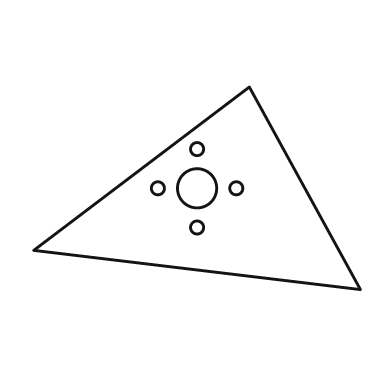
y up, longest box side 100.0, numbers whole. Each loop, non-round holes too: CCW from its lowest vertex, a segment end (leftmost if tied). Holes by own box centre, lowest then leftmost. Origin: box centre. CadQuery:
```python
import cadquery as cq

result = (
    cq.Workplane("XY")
    .moveTo(50.0, -31.0)
    .lineTo(16.0, 31.0)
    .lineTo(-50.0, -19.0)
    .close()
    .moveTo(0.0, -12.0)
    .circle(2.0)
    .moveTo(-12.0, 0.0)
    .circle(2.0)
    .moveTo(0.0, 0.0)
    .circle(6.0)
    .moveTo(12.0, 0.0)
    .circle(2.0)
    .moveTo(0.0, 12.0)
    .circle(2.0)
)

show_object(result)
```